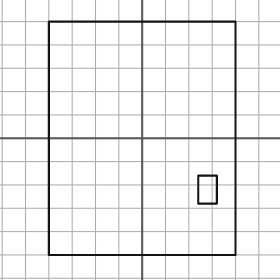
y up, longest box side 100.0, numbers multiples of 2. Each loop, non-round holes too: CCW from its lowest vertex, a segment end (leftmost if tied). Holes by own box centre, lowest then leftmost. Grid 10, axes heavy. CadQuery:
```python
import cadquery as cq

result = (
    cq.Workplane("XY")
    .moveTo(-40.0, -50.0)
    .lineTo(40.0, -50.0)
    .lineTo(40.0, 50.0)
    .lineTo(-40.0, 50.0)
    .close()
    .moveTo(24.0, -28.0)
    .lineTo(32.0, -28.0)
    .lineTo(32.0, -16.0)
    .lineTo(24.0, -16.0)
    .close()
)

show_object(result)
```